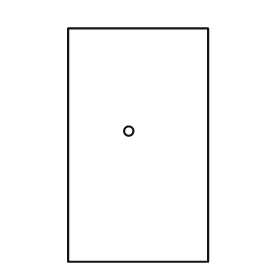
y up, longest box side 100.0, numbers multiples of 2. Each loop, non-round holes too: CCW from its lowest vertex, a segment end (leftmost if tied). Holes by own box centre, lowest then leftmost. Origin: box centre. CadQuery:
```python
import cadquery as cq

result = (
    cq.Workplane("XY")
    .moveTo(-30.0, -50.0)
    .lineTo(30.0, -50.0)
    .lineTo(30.0, 50.0)
    .lineTo(-30.0, 50.0)
    .close()
    .moveTo(-4.0, 6.0)
    .circle(2.0)
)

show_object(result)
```